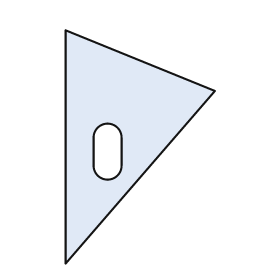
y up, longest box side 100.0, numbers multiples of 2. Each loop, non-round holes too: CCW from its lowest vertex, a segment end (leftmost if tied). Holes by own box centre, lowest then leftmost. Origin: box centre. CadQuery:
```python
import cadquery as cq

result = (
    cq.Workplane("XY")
    .moveTo(-32.0, -50.0)
    .lineTo(32.0, 24.0)
    .lineTo(-32.0, 50.0)
    .close()
    .moveTo(-20.0, -8.0)
    .threePointArc((-14.0, -14.0), (-8.0, -8.0))
    .lineTo(-8.0, 4.0)
    .threePointArc((-14.0, 10.0), (-20.0, 4.0))
    .close()
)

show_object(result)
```